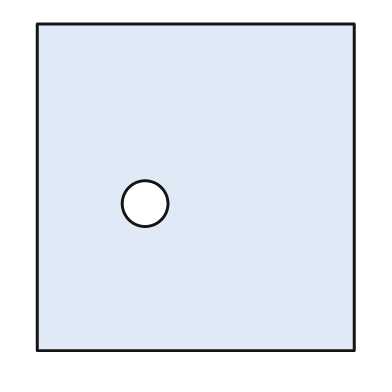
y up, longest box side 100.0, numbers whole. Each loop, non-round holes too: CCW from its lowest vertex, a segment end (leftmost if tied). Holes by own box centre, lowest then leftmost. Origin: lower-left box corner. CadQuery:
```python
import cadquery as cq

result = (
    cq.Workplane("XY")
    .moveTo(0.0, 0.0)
    .lineTo(97.0, 0.0)
    .lineTo(97.0, 100.0)
    .lineTo(0.0, 100.0)
    .close()
    .moveTo(33.0, 45.0)
    .circle(7.0)
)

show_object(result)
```